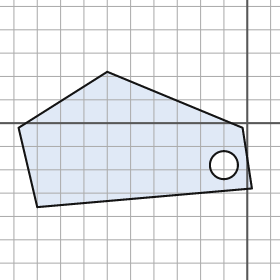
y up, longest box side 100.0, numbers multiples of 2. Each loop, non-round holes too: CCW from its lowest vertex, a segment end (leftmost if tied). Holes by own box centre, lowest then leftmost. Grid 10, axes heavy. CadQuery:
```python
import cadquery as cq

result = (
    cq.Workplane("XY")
    .moveTo(-90.0, -36.0)
    .lineTo(2.0, -28.0)
    .lineTo(-2.0, -2.0)
    .lineTo(-60.0, 22.0)
    .lineTo(-98.0, -2.0)
    .close()
    .moveTo(-10.0, -18.0)
    .circle(6.0)
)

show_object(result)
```